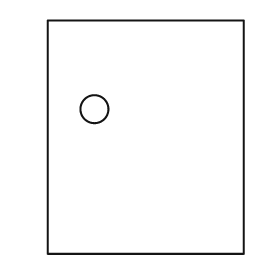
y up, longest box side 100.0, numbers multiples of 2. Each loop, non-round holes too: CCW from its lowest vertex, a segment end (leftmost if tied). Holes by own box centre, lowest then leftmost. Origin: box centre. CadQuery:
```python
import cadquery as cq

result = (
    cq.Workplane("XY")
    .moveTo(-42.0, -50.0)
    .lineTo(42.0, -50.0)
    .lineTo(42.0, 50.0)
    .lineTo(-42.0, 50.0)
    .close()
    .moveTo(-22.0, 12.0)
    .circle(6.0)
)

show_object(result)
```